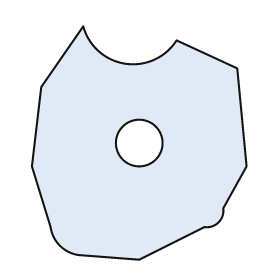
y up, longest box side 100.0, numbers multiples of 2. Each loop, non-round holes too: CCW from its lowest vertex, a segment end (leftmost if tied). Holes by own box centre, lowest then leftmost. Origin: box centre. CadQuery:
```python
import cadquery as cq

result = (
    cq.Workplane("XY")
    .moveTo(0.0, -50.0)
    .lineTo(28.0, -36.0)
    .threePointArc((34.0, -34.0), (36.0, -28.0))
    .lineTo(46.0, -10.0)
    .lineTo(42.0, 32.0)
    .lineTo(16.0, 44.0)
    .threePointArc((-6.0, 34.0), (-24.0, 50.0))
    .lineTo(-42.0, 24.0)
    .lineTo(-46.0, -10.0)
    .lineTo(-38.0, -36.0)
    .threePointArc((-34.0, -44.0), (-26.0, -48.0))
    .close()
    .moveTo(0.0, 0.0)
    .circle(10.0)
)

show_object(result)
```